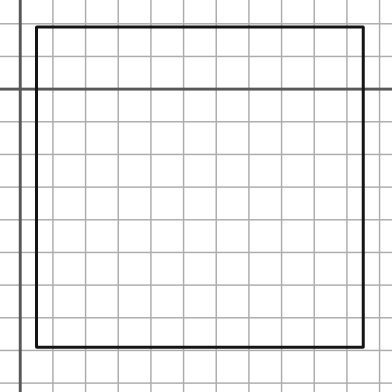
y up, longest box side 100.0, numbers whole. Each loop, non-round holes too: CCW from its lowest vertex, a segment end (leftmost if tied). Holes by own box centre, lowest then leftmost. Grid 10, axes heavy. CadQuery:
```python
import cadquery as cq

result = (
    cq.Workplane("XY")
    .moveTo(5.0, -79.0)
    .lineTo(105.0, -79.0)
    .lineTo(105.0, 19.0)
    .lineTo(5.0, 19.0)
    .close()
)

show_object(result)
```